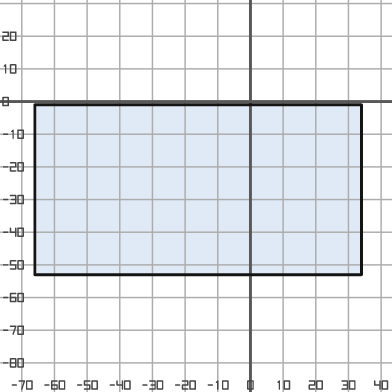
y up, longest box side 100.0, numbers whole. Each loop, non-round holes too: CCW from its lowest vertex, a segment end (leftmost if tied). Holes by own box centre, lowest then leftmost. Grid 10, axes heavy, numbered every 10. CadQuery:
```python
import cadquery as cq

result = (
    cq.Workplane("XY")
    .moveTo(-66.0, -53.0)
    .lineTo(34.0, -53.0)
    .lineTo(34.0, -1.0)
    .lineTo(-66.0, -1.0)
    .close()
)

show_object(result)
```